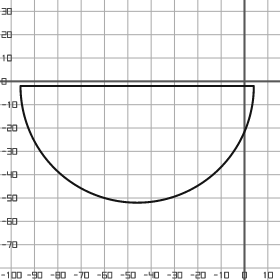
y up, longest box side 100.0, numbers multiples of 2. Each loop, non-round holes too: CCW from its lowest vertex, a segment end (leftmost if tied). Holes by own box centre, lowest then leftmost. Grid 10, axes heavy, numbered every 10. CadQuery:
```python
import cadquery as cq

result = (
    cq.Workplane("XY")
    .moveTo(-96.0, -2.0)
    .threePointArc((-46.0, -52.0), (4.0, -2.0))
    .close()
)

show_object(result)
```